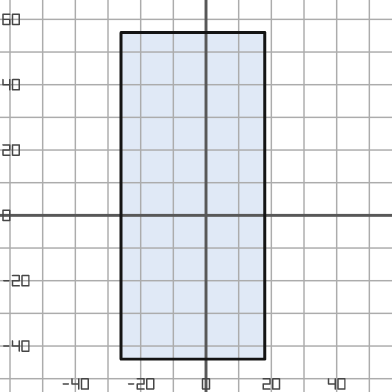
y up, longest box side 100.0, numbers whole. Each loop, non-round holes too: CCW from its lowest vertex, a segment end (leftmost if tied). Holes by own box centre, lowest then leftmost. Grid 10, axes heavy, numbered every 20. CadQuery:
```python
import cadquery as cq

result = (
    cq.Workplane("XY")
    .moveTo(-26.0, -44.0)
    .lineTo(18.0, -44.0)
    .lineTo(18.0, 56.0)
    .lineTo(-26.0, 56.0)
    .close()
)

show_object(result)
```